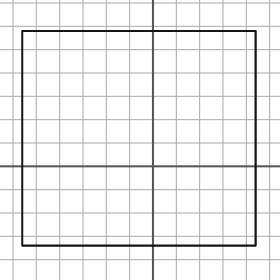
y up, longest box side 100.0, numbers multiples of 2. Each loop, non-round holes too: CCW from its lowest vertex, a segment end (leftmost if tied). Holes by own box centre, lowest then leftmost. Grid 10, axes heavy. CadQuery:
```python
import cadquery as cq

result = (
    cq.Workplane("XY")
    .moveTo(-56.0, -34.0)
    .lineTo(44.0, -34.0)
    .lineTo(44.0, 58.0)
    .lineTo(-56.0, 58.0)
    .close()
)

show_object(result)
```